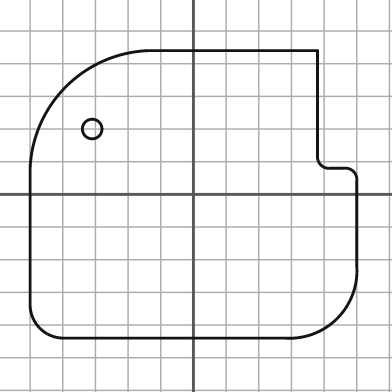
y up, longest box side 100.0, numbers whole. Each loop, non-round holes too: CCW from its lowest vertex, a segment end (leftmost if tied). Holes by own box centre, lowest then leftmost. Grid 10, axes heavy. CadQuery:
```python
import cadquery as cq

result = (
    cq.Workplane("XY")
    .moveTo(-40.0, -44.0)
    .lineTo(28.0, -44.0)
    .threePointArc((44.0, -38.0), (50.0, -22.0))
    .lineTo(50.0, 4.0)
    .threePointArc((49.0, 7.0), (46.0, 8.0))
    .lineTo(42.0, 8.0)
    .threePointArc((39.0, 9.0), (38.0, 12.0))
    .lineTo(38.0, 44.0)
    .lineTo(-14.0, 44.0)
    .threePointArc((-39.0, 33.0), (-50.0, 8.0))
    .lineTo(-50.0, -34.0)
    .threePointArc((-47.0, -41.0), (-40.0, -44.0))
    .close()
    .moveTo(-31.0, 20.0)
    .circle(3.0)
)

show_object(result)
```